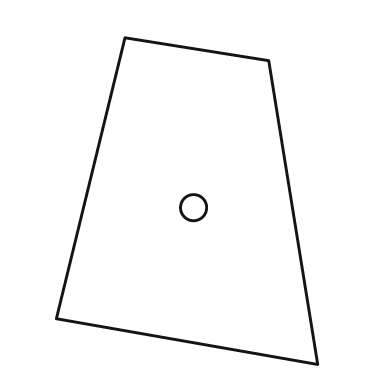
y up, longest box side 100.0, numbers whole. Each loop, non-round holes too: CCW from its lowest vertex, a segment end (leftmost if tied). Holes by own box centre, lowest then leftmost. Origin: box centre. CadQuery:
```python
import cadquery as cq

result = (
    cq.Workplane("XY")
    .moveTo(40.0, -50.0)
    .lineTo(25.0, 43.0)
    .lineTo(-19.0, 50.0)
    .lineTo(-40.0, -36.0)
    .close()
    .moveTo(2.0, -2.0)
    .circle(4.0)
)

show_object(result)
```